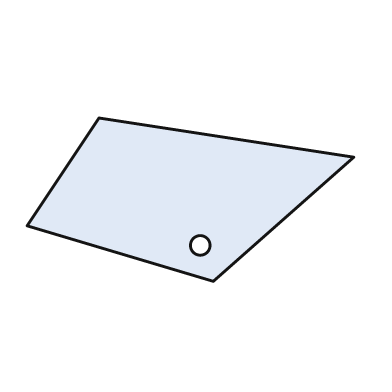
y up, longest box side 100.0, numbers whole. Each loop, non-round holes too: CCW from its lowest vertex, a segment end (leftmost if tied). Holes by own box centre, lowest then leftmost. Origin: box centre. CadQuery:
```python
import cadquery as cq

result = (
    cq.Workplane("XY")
    .moveTo(7.0, -25.0)
    .lineTo(50.0, 13.0)
    .lineTo(-28.0, 25.0)
    .lineTo(-50.0, -8.0)
    .close()
    .moveTo(3.0, -14.0)
    .circle(3.0)
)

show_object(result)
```